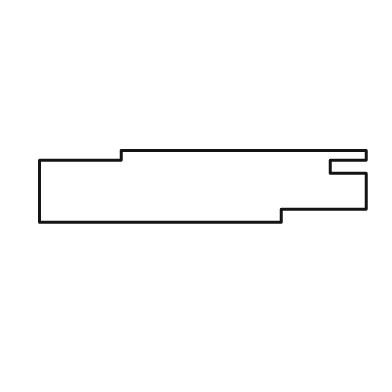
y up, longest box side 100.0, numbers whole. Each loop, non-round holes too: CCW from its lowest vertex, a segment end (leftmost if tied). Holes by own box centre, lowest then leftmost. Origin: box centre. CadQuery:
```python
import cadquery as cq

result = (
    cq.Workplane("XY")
    .moveTo(-50.0, -11.0)
    .lineTo(24.0, -11.0)
    .lineTo(24.0, -7.0)
    .lineTo(50.0, -7.0)
    .lineTo(50.0, 4.0)
    .lineTo(39.0, 4.0)
    .lineTo(39.0, 8.0)
    .lineTo(50.0, 8.0)
    .lineTo(50.0, 11.0)
    .lineTo(-25.0, 11.0)
    .lineTo(-25.0, 8.0)
    .lineTo(-50.0, 8.0)
    .close()
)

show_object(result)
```